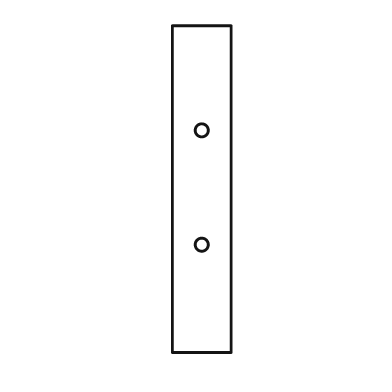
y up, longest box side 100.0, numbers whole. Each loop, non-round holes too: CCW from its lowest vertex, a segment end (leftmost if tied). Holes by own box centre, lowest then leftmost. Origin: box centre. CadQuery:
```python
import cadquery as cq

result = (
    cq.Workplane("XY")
    .moveTo(-9.0, -50.0)
    .lineTo(9.0, -50.0)
    .lineTo(9.0, 50.0)
    .lineTo(-9.0, 50.0)
    .close()
    .moveTo(0.0, -17.0)
    .circle(2.0)
    .moveTo(0.0, 18.0)
    .circle(2.0)
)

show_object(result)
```